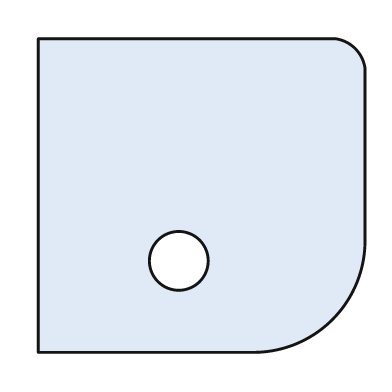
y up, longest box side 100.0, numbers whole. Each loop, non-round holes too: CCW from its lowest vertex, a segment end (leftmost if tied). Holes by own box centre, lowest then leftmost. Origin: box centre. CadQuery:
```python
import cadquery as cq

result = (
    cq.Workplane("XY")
    .moveTo(-50.0, -48.0)
    .lineTo(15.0, -48.0)
    .threePointArc((40.0, -38.0), (50.0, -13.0))
    .lineTo(50.0, 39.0)
    .threePointArc((47.0, 45.0), (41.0, 48.0))
    .lineTo(-50.0, 48.0)
    .close()
    .moveTo(-7.0, -20.0)
    .circle(9.0)
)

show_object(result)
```